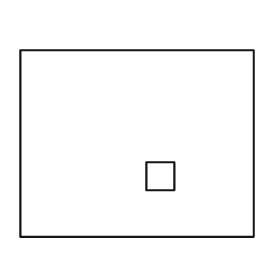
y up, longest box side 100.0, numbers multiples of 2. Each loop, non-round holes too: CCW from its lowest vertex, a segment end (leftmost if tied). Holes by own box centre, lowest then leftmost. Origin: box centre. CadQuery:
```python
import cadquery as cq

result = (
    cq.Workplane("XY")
    .moveTo(-50.0, -40.0)
    .lineTo(50.0, -40.0)
    .lineTo(50.0, 40.0)
    .lineTo(-50.0, 40.0)
    .close()
    .moveTo(4.0, -20.0)
    .lineTo(16.0, -20.0)
    .lineTo(16.0, -8.0)
    .lineTo(4.0, -8.0)
    .close()
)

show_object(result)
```